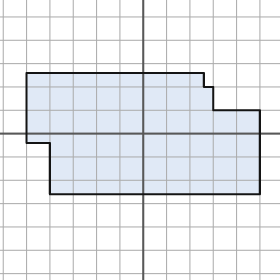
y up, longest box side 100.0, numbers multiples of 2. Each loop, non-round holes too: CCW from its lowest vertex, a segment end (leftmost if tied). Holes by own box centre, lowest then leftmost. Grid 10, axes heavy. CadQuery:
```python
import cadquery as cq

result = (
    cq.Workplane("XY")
    .moveTo(-40.0, -26.0)
    .lineTo(50.0, -26.0)
    .lineTo(50.0, 10.0)
    .lineTo(30.0, 10.0)
    .lineTo(30.0, 20.0)
    .lineTo(26.0, 20.0)
    .lineTo(26.0, 26.0)
    .lineTo(-50.0, 26.0)
    .lineTo(-50.0, -4.0)
    .lineTo(-40.0, -4.0)
    .close()
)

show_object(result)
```